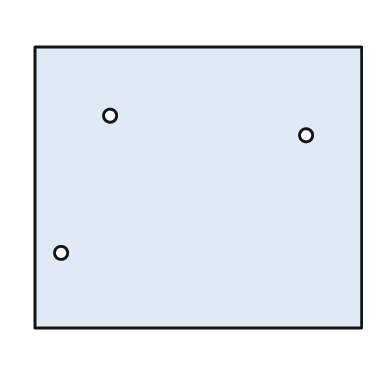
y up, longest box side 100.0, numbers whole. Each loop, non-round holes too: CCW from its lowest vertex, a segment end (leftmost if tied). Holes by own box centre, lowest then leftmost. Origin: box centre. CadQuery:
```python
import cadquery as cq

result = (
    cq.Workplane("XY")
    .moveTo(-50.0, -43.0)
    .lineTo(50.0, -43.0)
    .lineTo(50.0, 43.0)
    .lineTo(-50.0, 43.0)
    .close()
    .moveTo(-42.0, -20.0)
    .circle(2.0)
    .moveTo(33.0, 16.0)
    .circle(2.0)
    .moveTo(-27.0, 22.0)
    .circle(2.0)
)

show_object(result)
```